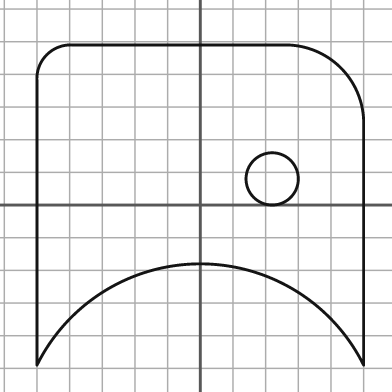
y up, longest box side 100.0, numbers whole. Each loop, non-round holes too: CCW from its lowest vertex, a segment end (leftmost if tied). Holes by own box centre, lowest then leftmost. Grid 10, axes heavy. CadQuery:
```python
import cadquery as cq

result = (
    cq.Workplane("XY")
    .moveTo(-50.0, -49.0)
    .threePointArc((0.0, -18.0), (50.0, -49.0))
    .lineTo(50.0, 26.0)
    .threePointArc((43.0, 42.0), (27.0, 49.0))
    .lineTo(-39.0, 49.0)
    .threePointArc((-47.0, 46.0), (-50.0, 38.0))
    .close()
    .moveTo(22.0, 8.0)
    .circle(8.0)
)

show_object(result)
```